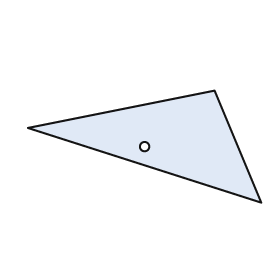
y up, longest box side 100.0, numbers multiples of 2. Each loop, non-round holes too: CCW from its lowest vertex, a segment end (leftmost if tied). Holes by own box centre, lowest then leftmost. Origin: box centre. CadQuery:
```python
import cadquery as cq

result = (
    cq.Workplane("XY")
    .moveTo(50.0, -24.0)
    .lineTo(30.0, 24.0)
    .lineTo(-50.0, 8.0)
    .close()
    .moveTo(0.0, 0.0)
    .circle(2.0)
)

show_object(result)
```